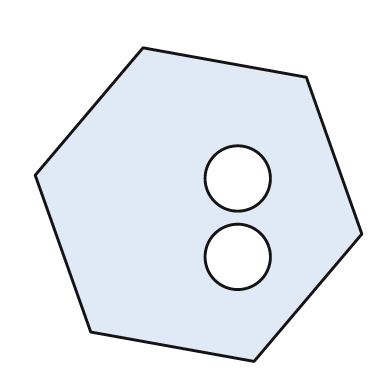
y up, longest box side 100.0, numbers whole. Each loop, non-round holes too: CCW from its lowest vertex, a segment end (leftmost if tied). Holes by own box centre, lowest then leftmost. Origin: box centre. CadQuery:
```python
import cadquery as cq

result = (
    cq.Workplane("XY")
    .moveTo(17.0, -48.0)
    .lineTo(50.0, -9.0)
    .lineTo(33.0, 39.0)
    .lineTo(-17.0, 48.0)
    .lineTo(-50.0, 9.0)
    .lineTo(-33.0, -39.0)
    .close()
    .moveTo(12.0, -16.0)
    .circle(10.0)
    .moveTo(12.0, 8.0)
    .circle(10.0)
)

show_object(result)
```